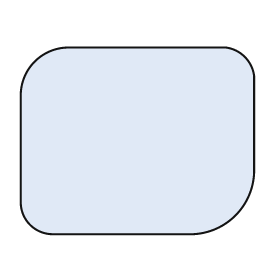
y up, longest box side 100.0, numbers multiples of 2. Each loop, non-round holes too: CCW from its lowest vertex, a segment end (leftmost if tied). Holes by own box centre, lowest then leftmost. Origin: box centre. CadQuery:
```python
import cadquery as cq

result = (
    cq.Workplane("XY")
    .moveTo(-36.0, -40.0)
    .lineTo(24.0, -40.0)
    .threePointArc((42.0, -32.0), (50.0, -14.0))
    .lineTo(50.0, 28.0)
    .threePointArc((46.0, 36.0), (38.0, 40.0))
    .lineTo(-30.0, 40.0)
    .threePointArc((-44.0, 34.0), (-50.0, 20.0))
    .lineTo(-50.0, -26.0)
    .threePointArc((-46.0, -36.0), (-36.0, -40.0))
    .close()
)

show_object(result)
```